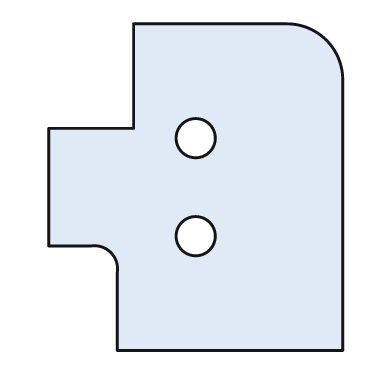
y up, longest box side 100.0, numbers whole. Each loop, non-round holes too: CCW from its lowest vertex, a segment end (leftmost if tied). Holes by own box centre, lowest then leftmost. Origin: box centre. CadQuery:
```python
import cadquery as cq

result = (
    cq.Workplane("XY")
    .moveTo(-24.0, -50.0)
    .lineTo(45.0, -50.0)
    .lineTo(45.0, 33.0)
    .threePointArc((40.0, 45.0), (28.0, 50.0))
    .lineTo(-19.0, 50.0)
    .lineTo(-19.0, 18.0)
    .lineTo(-45.0, 18.0)
    .lineTo(-45.0, -18.0)
    .lineTo(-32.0, -18.0)
    .threePointArc((-26.0, -20.0), (-24.0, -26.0))
    .close()
    .moveTo(0.0, -15.0)
    .circle(6.0)
    .moveTo(0.0, 15.0)
    .circle(6.0)
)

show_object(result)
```